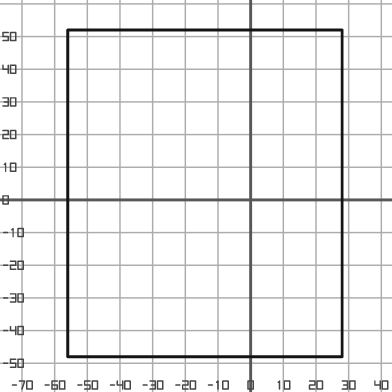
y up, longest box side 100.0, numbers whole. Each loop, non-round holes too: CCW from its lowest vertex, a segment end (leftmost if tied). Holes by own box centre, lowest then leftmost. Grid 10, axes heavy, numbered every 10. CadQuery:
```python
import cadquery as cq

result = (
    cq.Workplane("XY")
    .moveTo(-56.0, -48.0)
    .lineTo(28.0, -48.0)
    .lineTo(28.0, 52.0)
    .lineTo(-56.0, 52.0)
    .close()
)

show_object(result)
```